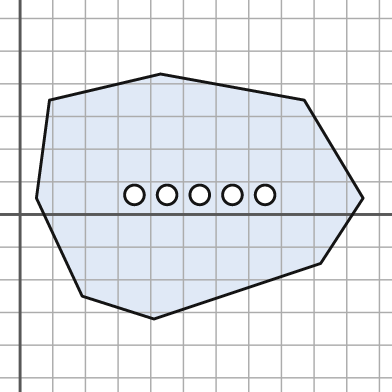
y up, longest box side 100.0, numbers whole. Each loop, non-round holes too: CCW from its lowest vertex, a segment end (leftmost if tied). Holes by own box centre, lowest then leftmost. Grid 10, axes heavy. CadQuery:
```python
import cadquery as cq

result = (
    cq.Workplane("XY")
    .moveTo(41.0, -32.0)
    .lineTo(92.0, -15.0)
    .lineTo(105.0, 5.0)
    .lineTo(87.0, 35.0)
    .lineTo(43.0, 43.0)
    .lineTo(9.0, 35.0)
    .lineTo(5.0, 5.0)
    .lineTo(19.0, -25.0)
    .close()
    .moveTo(35.0, 6.0)
    .circle(3.0)
    .moveTo(45.0, 6.0)
    .circle(3.0)
    .moveTo(55.0, 6.0)
    .circle(3.0)
    .moveTo(65.0, 6.0)
    .circle(3.0)
    .moveTo(75.0, 6.0)
    .circle(3.0)
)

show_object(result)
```